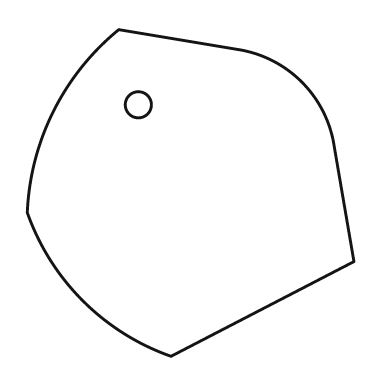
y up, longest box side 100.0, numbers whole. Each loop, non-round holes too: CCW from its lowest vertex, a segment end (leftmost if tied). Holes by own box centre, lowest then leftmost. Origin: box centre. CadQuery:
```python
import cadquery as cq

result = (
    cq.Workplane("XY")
    .moveTo(-6.0, -50.0)
    .lineTo(50.0, -21.0)
    .lineTo(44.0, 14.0)
    .threePointArc((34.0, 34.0), (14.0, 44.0))
    .lineTo(-22.0, 50.0)
    .threePointArc((-42.0, 25.0), (-50.0, -6.0))
    .threePointArc((-33.0, -33.0), (-6.0, -50.0))
    .close()
    .moveTo(-16.0, 27.0)
    .circle(4.0)
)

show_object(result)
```